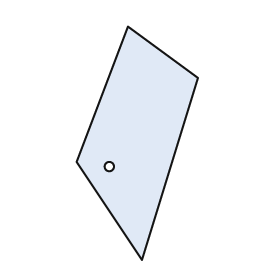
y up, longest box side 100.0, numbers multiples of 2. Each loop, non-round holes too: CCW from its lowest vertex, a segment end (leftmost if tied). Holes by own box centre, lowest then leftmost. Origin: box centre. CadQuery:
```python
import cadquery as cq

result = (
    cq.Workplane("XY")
    .moveTo(2.0, -50.0)
    .lineTo(26.0, 28.0)
    .lineTo(-4.0, 50.0)
    .lineTo(-26.0, -8.0)
    .close()
    .moveTo(-12.0, -10.0)
    .circle(2.0)
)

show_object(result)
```